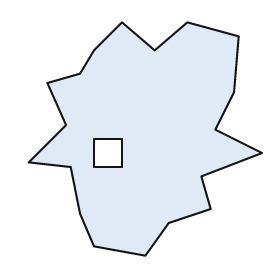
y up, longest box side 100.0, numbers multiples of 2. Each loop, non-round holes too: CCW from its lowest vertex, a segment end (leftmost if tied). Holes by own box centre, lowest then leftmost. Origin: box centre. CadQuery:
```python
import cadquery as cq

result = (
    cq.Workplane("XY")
    .moveTo(0.0, -50.0)
    .lineTo(10.0, -36.0)
    .lineTo(28.0, -30.0)
    .lineTo(24.0, -16.0)
    .lineTo(50.0, -6.0)
    .lineTo(30.0, 4.0)
    .lineTo(38.0, 20.0)
    .lineTo(40.0, 44.0)
    .lineTo(18.0, 50.0)
    .lineTo(4.0, 38.0)
    .lineTo(-10.0, 50.0)
    .lineTo(-22.0, 38.0)
    .lineTo(-28.0, 28.0)
    .lineTo(-42.0, 24.0)
    .lineTo(-34.0, 6.0)
    .lineTo(-50.0, -10.0)
    .lineTo(-32.0, -12.0)
    .lineTo(-28.0, -32.0)
    .lineTo(-22.0, -46.0)
    .close()
    .moveTo(-22.0, -12.0)
    .lineTo(-10.0, -12.0)
    .lineTo(-10.0, 0.0)
    .lineTo(-22.0, 0.0)
    .close()
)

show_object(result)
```